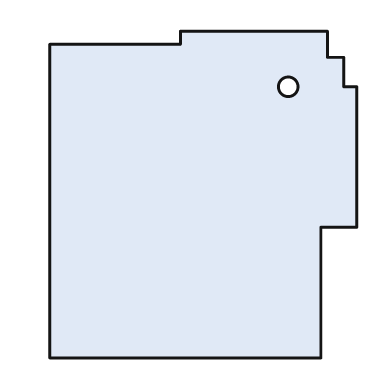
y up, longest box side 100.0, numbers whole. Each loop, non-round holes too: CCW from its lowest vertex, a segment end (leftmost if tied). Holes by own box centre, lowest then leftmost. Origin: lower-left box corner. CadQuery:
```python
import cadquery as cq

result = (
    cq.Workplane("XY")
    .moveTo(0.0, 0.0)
    .lineTo(83.0, 0.0)
    .lineTo(83.0, 40.0)
    .lineTo(94.0, 40.0)
    .lineTo(94.0, 83.0)
    .lineTo(90.0, 83.0)
    .lineTo(90.0, 92.0)
    .lineTo(85.0, 92.0)
    .lineTo(85.0, 100.0)
    .lineTo(40.0, 100.0)
    .lineTo(40.0, 96.0)
    .lineTo(0.0, 96.0)
    .close()
    .moveTo(73.0, 83.0)
    .circle(3.0)
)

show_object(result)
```